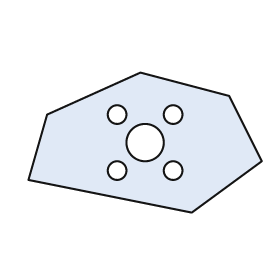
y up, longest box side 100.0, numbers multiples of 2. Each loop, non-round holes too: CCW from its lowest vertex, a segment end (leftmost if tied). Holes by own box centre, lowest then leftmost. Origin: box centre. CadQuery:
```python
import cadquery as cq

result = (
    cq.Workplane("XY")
    .moveTo(20.0, -30.0)
    .lineTo(50.0, -8.0)
    .lineTo(36.0, 20.0)
    .lineTo(-2.0, 30.0)
    .lineTo(-42.0, 12.0)
    .lineTo(-50.0, -16.0)
    .close()
    .moveTo(-12.0, -12.0)
    .circle(4.0)
    .moveTo(12.0, -12.0)
    .circle(4.0)
    .moveTo(0.0, 0.0)
    .circle(8.0)
    .moveTo(-12.0, 12.0)
    .circle(4.0)
    .moveTo(12.0, 12.0)
    .circle(4.0)
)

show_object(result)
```